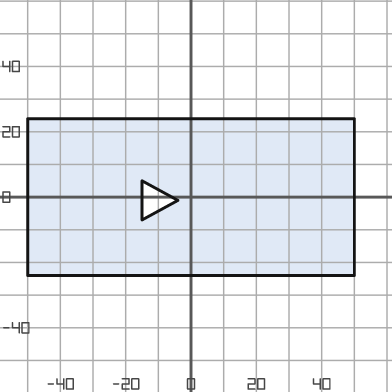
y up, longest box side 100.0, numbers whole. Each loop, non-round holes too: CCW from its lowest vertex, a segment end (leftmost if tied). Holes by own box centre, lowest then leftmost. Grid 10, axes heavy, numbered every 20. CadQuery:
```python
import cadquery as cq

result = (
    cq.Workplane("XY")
    .moveTo(-50.0, -24.0)
    .lineTo(50.0, -24.0)
    .lineTo(50.0, 24.0)
    .lineTo(-50.0, 24.0)
    .close()
    .moveTo(-15.0, -7.0)
    .lineTo(-4.0, -1.0)
    .lineTo(-15.0, 5.0)
    .close()
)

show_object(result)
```